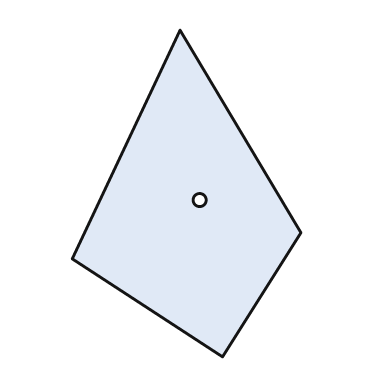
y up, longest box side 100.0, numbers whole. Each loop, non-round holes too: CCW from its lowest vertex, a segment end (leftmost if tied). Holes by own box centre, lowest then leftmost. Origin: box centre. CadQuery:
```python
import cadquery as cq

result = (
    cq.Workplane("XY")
    .moveTo(11.0, -50.0)
    .lineTo(35.0, -12.0)
    .lineTo(-2.0, 50.0)
    .lineTo(-35.0, -20.0)
    .close()
    .moveTo(4.0, -2.0)
    .circle(2.0)
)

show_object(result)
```